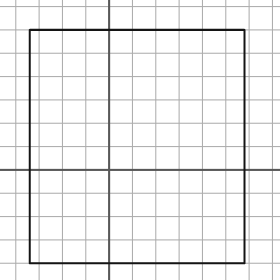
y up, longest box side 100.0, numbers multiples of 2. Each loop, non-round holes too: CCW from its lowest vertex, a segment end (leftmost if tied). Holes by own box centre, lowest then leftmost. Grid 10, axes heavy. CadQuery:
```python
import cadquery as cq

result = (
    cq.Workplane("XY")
    .moveTo(-34.0, -40.0)
    .lineTo(58.0, -40.0)
    .lineTo(58.0, 60.0)
    .lineTo(-34.0, 60.0)
    .close()
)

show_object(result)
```